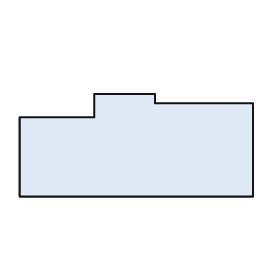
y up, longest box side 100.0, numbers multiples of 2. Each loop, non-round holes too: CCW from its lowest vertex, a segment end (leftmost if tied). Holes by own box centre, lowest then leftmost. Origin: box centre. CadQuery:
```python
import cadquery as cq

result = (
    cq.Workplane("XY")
    .moveTo(-50.0, -22.0)
    .lineTo(50.0, -22.0)
    .lineTo(50.0, 18.0)
    .lineTo(8.0, 18.0)
    .lineTo(8.0, 22.0)
    .lineTo(-18.0, 22.0)
    .lineTo(-18.0, 12.0)
    .lineTo(-50.0, 12.0)
    .close()
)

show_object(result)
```